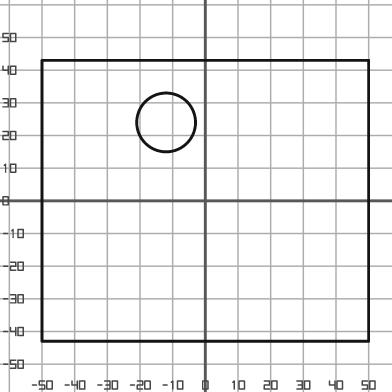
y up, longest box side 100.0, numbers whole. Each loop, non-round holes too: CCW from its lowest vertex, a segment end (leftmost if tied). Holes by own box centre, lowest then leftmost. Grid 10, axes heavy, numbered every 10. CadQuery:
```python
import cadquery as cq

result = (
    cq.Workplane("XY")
    .moveTo(-50.0, -43.0)
    .lineTo(50.0, -43.0)
    .lineTo(50.0, 43.0)
    .lineTo(-50.0, 43.0)
    .close()
    .moveTo(-12.0, 24.0)
    .circle(9.0)
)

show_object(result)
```